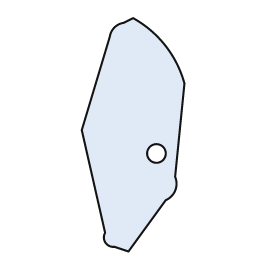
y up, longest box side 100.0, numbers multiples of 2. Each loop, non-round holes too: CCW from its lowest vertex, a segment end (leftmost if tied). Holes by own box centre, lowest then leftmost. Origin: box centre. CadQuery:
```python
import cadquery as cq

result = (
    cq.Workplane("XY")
    .moveTo(-2.0, -50.0)
    .lineTo(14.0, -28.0)
    .threePointArc((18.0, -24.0), (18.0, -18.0))
    .lineTo(22.0, 22.0)
    .threePointArc((14.0, 38.0), (0.0, 50.0))
    .lineTo(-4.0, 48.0)
    .threePointArc((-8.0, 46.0), (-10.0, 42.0))
    .lineTo(-22.0, 2.0)
    .lineTo(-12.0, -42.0)
    .threePointArc((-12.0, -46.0), (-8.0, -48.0))
    .close()
    .moveTo(10.0, -8.0)
    .circle(4.0)
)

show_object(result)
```